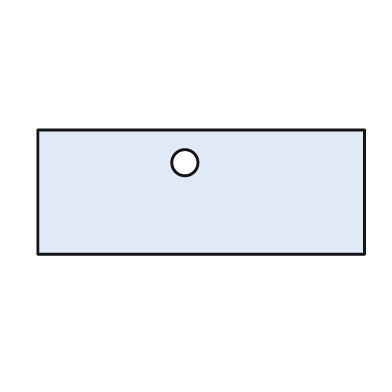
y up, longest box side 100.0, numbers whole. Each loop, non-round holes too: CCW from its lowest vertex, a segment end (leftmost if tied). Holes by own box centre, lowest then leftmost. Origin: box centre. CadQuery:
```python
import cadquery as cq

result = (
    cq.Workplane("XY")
    .moveTo(-50.0, -19.0)
    .lineTo(50.0, -19.0)
    .lineTo(50.0, 19.0)
    .lineTo(-50.0, 19.0)
    .close()
    .moveTo(-5.0, 9.0)
    .circle(4.0)
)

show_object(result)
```